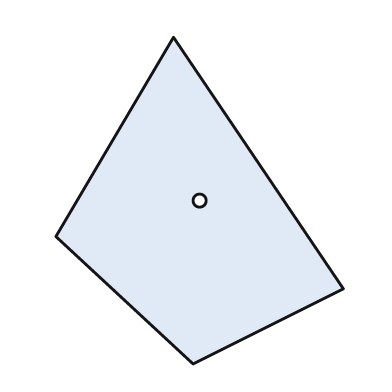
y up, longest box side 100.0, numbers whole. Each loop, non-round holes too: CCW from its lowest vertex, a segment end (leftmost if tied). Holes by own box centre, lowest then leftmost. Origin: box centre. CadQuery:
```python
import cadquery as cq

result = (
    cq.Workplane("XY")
    .moveTo(-2.0, -50.0)
    .lineTo(44.0, -27.0)
    .lineTo(-8.0, 50.0)
    .lineTo(-44.0, -11.0)
    .close()
    .moveTo(0.0, 0.0)
    .circle(2.0)
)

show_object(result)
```